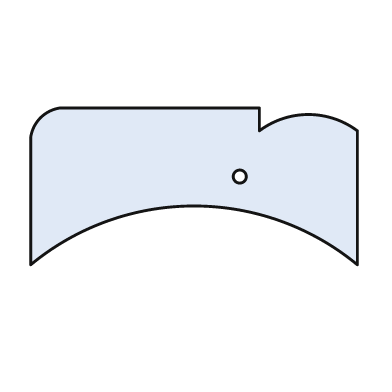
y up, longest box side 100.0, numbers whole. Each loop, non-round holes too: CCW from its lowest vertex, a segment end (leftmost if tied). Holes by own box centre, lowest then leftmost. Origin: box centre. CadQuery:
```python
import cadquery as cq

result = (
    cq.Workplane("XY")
    .moveTo(-50.0, -24.0)
    .threePointArc((0.0, -6.0), (50.0, -24.0))
    .lineTo(50.0, 17.0)
    .threePointArc((35.0, 22.0), (20.0, 17.0))
    .lineTo(20.0, 24.0)
    .lineTo(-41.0, 24.0)
    .threePointArc((-47.0, 21.0), (-50.0, 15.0))
    .close()
    .moveTo(14.0, 3.0)
    .circle(2.0)
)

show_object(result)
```